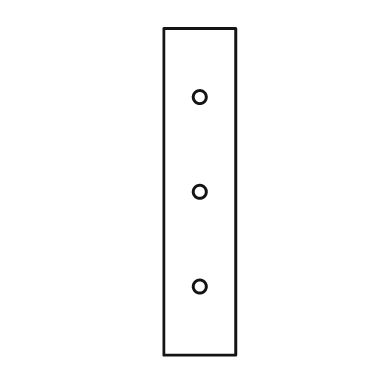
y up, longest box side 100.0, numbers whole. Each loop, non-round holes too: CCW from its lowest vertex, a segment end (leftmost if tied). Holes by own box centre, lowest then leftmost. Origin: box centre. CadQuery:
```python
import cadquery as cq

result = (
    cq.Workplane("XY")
    .moveTo(-11.0, -50.0)
    .lineTo(11.0, -50.0)
    .lineTo(11.0, 50.0)
    .lineTo(-11.0, 50.0)
    .close()
    .moveTo(0.0, -29.0)
    .circle(2.0)
    .moveTo(0.0, 0.0)
    .circle(2.0)
    .moveTo(0.0, 29.0)
    .circle(2.0)
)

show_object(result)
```